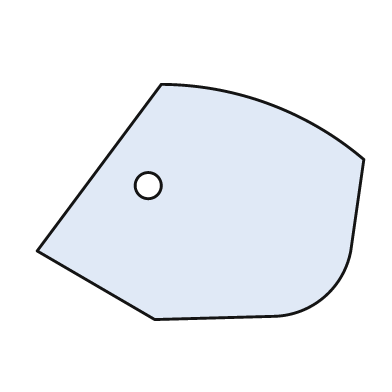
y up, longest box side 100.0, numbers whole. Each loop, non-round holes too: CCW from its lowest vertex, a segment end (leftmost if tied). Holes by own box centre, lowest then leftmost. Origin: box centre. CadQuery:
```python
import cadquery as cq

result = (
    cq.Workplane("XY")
    .moveTo(-14.0, -36.0)
    .lineTo(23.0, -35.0)
    .threePointArc((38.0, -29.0), (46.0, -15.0))
    .lineTo(50.0, 13.0)
    .threePointArc((21.0, 30.0), (-12.0, 36.0))
    .lineTo(-50.0, -15.0)
    .close()
    .moveTo(-16.0, 5.0)
    .circle(4.0)
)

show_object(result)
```